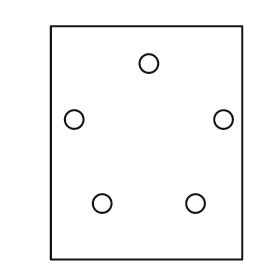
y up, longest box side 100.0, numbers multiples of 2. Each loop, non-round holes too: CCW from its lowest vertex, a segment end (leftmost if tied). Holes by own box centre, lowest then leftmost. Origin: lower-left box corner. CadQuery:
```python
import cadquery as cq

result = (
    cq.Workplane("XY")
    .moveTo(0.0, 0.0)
    .lineTo(82.0, 0.0)
    .lineTo(82.0, 100.0)
    .lineTo(0.0, 100.0)
    .close()
    .moveTo(22.0, 24.0)
    .circle(4.0)
    .moveTo(62.0, 24.0)
    .circle(4.0)
    .moveTo(10.0, 60.0)
    .circle(4.0)
    .moveTo(74.0, 60.0)
    .circle(4.0)
    .moveTo(42.0, 84.0)
    .circle(4.0)
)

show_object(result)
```